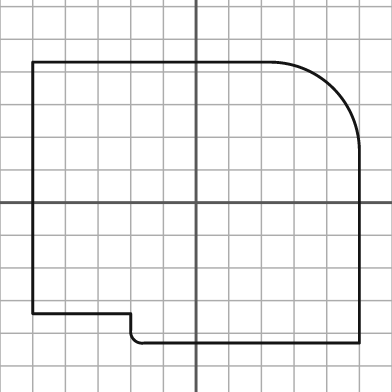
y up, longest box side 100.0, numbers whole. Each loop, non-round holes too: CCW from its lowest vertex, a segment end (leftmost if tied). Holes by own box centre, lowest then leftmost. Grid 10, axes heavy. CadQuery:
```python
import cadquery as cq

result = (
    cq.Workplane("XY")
    .moveTo(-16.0, -43.0)
    .lineTo(50.0, -43.0)
    .lineTo(50.0, 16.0)
    .threePointArc((42.0, 35.0), (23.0, 43.0))
    .lineTo(-50.0, 43.0)
    .lineTo(-50.0, -34.0)
    .lineTo(-20.0, -34.0)
    .lineTo(-20.0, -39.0)
    .threePointArc((-19.0, -42.0), (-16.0, -43.0))
    .close()
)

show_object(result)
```